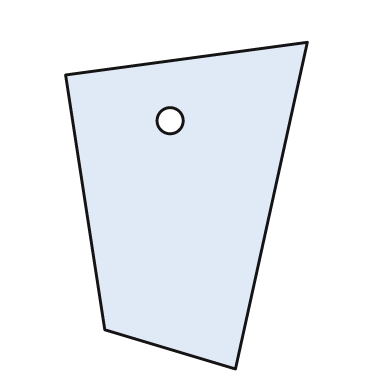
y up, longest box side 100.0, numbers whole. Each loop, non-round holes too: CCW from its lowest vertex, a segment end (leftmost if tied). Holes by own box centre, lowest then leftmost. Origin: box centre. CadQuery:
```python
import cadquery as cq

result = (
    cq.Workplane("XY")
    .moveTo(15.0, -50.0)
    .lineTo(37.0, 50.0)
    .lineTo(-37.0, 40.0)
    .lineTo(-25.0, -38.0)
    .close()
    .moveTo(-5.0, 26.0)
    .circle(4.0)
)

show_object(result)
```